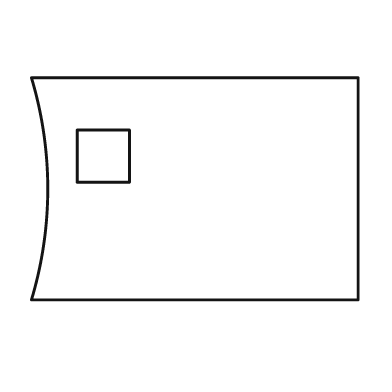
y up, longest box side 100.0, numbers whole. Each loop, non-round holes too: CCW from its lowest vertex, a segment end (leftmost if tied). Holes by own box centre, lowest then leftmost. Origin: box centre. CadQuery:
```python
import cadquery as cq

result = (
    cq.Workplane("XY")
    .moveTo(-50.0, -34.0)
    .lineTo(50.0, -34.0)
    .lineTo(50.0, 34.0)
    .lineTo(-50.0, 34.0)
    .threePointArc((-45.0, 0.0), (-50.0, -34.0))
    .close()
    .moveTo(-36.0, 2.0)
    .lineTo(-20.0, 2.0)
    .lineTo(-20.0, 18.0)
    .lineTo(-36.0, 18.0)
    .close()
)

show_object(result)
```